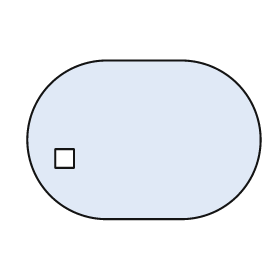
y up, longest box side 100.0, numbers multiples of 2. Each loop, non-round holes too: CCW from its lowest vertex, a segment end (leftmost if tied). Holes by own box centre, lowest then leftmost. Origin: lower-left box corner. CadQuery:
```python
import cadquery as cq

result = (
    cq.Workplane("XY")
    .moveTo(34.0, 0.0)
    .lineTo(66.0, 0.0)
    .threePointArc((100.0, 34.0), (66.0, 68.0))
    .lineTo(34.0, 68.0)
    .threePointArc((0.0, 34.0), (34.0, 0.0))
    .close()
    .moveTo(12.0, 22.0)
    .lineTo(20.0, 22.0)
    .lineTo(20.0, 30.0)
    .lineTo(12.0, 30.0)
    .close()
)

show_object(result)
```